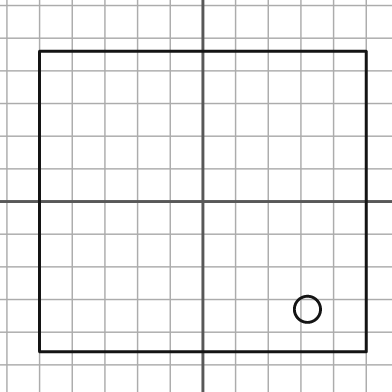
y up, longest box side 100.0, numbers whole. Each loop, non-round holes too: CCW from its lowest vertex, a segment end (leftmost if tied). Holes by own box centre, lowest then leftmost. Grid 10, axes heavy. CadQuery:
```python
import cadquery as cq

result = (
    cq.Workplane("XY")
    .moveTo(-50.0, -46.0)
    .lineTo(50.0, -46.0)
    .lineTo(50.0, 46.0)
    .lineTo(-50.0, 46.0)
    .close()
    .moveTo(32.0, -33.0)
    .circle(4.0)
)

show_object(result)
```